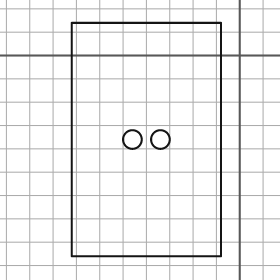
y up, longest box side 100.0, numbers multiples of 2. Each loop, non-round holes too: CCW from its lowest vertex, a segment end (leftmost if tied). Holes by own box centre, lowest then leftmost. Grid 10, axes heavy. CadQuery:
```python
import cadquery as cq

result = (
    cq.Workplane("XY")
    .moveTo(-72.0, -86.0)
    .lineTo(-8.0, -86.0)
    .lineTo(-8.0, 14.0)
    .lineTo(-72.0, 14.0)
    .close()
    .moveTo(-46.0, -36.0)
    .circle(4.0)
    .moveTo(-34.0, -36.0)
    .circle(4.0)
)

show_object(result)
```